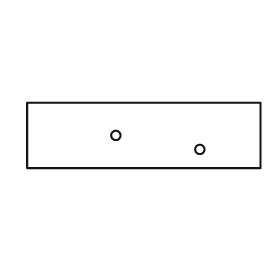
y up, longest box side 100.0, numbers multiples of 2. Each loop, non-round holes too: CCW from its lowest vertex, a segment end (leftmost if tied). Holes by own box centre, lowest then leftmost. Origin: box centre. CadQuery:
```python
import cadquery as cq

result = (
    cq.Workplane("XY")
    .moveTo(-50.0, -14.0)
    .lineTo(50.0, -14.0)
    .lineTo(50.0, 14.0)
    .lineTo(-50.0, 14.0)
    .close()
    .moveTo(24.0, -6.0)
    .circle(2.0)
    .moveTo(-12.0, 0.0)
    .circle(2.0)
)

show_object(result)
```